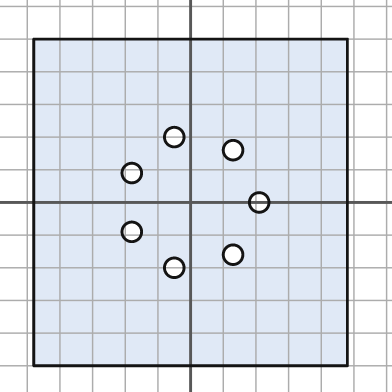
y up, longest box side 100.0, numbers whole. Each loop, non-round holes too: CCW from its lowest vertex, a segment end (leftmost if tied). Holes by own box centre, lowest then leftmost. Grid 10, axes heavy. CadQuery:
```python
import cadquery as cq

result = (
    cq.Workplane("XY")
    .moveTo(-48.0, -50.0)
    .lineTo(48.0, -50.0)
    .lineTo(48.0, 50.0)
    .lineTo(-48.0, 50.0)
    .close()
    .moveTo(-5.0, -20.0)
    .circle(3.0)
    .moveTo(13.0, -16.0)
    .circle(3.0)
    .moveTo(-18.0, -9.0)
    .circle(3.0)
    .moveTo(21.0, 0.0)
    .circle(3.0)
    .moveTo(-18.0, 9.0)
    .circle(3.0)
    .moveTo(13.0, 16.0)
    .circle(3.0)
    .moveTo(-5.0, 20.0)
    .circle(3.0)
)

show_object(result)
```